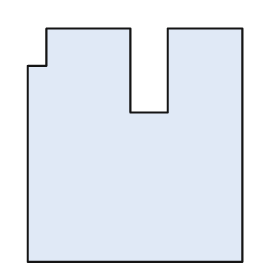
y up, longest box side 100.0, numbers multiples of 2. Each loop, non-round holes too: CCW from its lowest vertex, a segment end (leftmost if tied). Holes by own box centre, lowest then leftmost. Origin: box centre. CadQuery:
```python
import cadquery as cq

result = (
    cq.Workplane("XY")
    .moveTo(-46.0, -50.0)
    .lineTo(46.0, -50.0)
    .lineTo(46.0, 50.0)
    .lineTo(14.0, 50.0)
    .lineTo(14.0, 14.0)
    .lineTo(-2.0, 14.0)
    .lineTo(-2.0, 50.0)
    .lineTo(-38.0, 50.0)
    .lineTo(-38.0, 34.0)
    .lineTo(-46.0, 34.0)
    .close()
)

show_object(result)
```